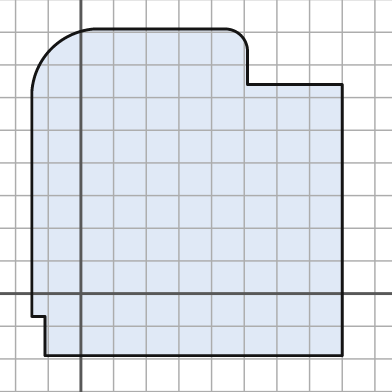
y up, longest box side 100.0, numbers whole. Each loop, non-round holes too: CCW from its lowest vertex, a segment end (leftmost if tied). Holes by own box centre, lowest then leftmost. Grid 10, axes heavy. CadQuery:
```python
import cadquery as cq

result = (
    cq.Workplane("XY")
    .moveTo(-11.0, -19.0)
    .lineTo(80.0, -19.0)
    .lineTo(80.0, 64.0)
    .lineTo(51.0, 64.0)
    .lineTo(51.0, 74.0)
    .threePointArc((49.0, 79.0), (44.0, 81.0))
    .lineTo(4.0, 81.0)
    .threePointArc((-9.0, 75.0), (-15.0, 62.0))
    .lineTo(-15.0, -7.0)
    .lineTo(-11.0, -7.0)
    .close()
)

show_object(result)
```